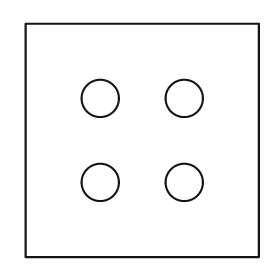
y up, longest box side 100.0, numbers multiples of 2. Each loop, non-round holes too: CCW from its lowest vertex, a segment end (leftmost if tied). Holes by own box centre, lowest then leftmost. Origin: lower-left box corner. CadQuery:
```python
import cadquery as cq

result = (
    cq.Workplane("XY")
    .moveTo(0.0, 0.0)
    .lineTo(100.0, 0.0)
    .lineTo(100.0, 100.0)
    .lineTo(0.0, 100.0)
    .close()
    .moveTo(32.0, 32.0)
    .circle(8.0)
    .moveTo(68.0, 32.0)
    .circle(8.0)
    .moveTo(32.0, 68.0)
    .circle(8.0)
    .moveTo(68.0, 68.0)
    .circle(8.0)
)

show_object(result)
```